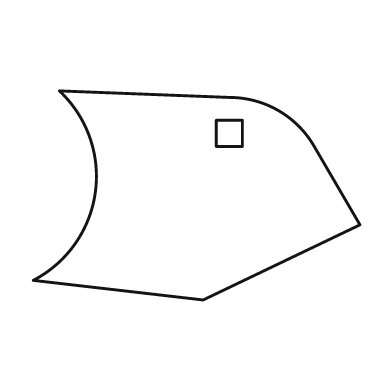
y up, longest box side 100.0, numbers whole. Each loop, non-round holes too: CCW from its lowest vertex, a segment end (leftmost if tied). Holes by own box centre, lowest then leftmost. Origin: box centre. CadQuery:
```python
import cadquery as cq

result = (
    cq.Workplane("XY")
    .moveTo(2.0, -32.0)
    .lineTo(50.0, -9.0)
    .lineTo(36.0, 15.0)
    .threePointArc((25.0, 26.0), (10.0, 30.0))
    .lineTo(-42.0, 32.0)
    .threePointArc((-31.0, 1.0), (-50.0, -26.0))
    .close()
    .moveTo(6.0, 15.0)
    .lineTo(14.0, 15.0)
    .lineTo(14.0, 23.0)
    .lineTo(6.0, 23.0)
    .close()
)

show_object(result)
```